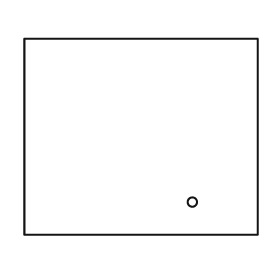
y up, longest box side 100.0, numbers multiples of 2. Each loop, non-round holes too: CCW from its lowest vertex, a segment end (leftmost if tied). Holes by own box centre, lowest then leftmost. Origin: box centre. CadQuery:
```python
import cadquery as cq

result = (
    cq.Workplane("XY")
    .moveTo(-50.0, -42.0)
    .lineTo(50.0, -42.0)
    .lineTo(50.0, 42.0)
    .lineTo(-50.0, 42.0)
    .close()
    .moveTo(22.0, -28.0)
    .circle(2.0)
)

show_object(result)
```